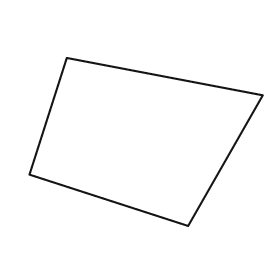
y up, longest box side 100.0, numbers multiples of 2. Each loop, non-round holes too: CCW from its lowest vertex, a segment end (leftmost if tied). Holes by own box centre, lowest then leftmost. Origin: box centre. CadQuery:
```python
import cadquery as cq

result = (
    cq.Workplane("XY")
    .moveTo(18.0, -36.0)
    .lineTo(50.0, 20.0)
    .lineTo(-34.0, 36.0)
    .lineTo(-50.0, -14.0)
    .close()
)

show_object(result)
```